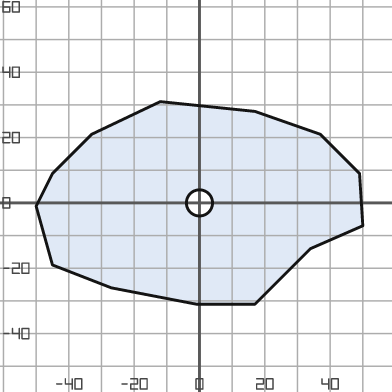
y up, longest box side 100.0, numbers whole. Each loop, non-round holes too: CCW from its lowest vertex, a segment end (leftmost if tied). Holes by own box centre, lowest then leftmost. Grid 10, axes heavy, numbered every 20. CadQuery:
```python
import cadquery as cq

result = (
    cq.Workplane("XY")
    .moveTo(-1.0, -31.0)
    .lineTo(17.0, -31.0)
    .lineTo(34.0, -14.0)
    .lineTo(50.0, -7.0)
    .lineTo(49.0, 9.0)
    .lineTo(37.0, 21.0)
    .lineTo(17.0, 28.0)
    .lineTo(-12.0, 31.0)
    .lineTo(-33.0, 21.0)
    .lineTo(-45.0, 9.0)
    .lineTo(-50.0, -1.0)
    .lineTo(-45.0, -19.0)
    .lineTo(-27.0, -26.0)
    .close()
    .moveTo(0.0, 0.0)
    .circle(4.0)
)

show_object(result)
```